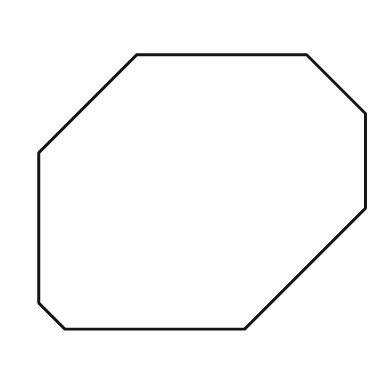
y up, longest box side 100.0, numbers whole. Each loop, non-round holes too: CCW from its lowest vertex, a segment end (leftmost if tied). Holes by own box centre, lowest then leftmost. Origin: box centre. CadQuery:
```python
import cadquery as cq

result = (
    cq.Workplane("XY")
    .moveTo(-42.0, -42.0)
    .lineTo(13.0, -42.0)
    .lineTo(50.0, -5.0)
    .lineTo(50.0, 24.0)
    .lineTo(32.0, 42.0)
    .lineTo(-20.0, 42.0)
    .lineTo(-50.0, 12.0)
    .lineTo(-50.0, -34.0)
    .close()
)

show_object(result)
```